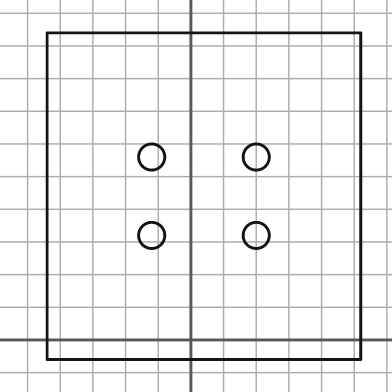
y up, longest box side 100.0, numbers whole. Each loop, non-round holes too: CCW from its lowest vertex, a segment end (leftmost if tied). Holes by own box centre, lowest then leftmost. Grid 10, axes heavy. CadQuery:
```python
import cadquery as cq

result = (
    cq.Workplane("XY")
    .moveTo(-44.0, -6.0)
    .lineTo(52.0, -6.0)
    .lineTo(52.0, 94.0)
    .lineTo(-44.0, 94.0)
    .close()
    .moveTo(-12.0, 32.0)
    .circle(4.0)
    .moveTo(20.0, 32.0)
    .circle(4.0)
    .moveTo(-12.0, 56.0)
    .circle(4.0)
    .moveTo(20.0, 56.0)
    .circle(4.0)
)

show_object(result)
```